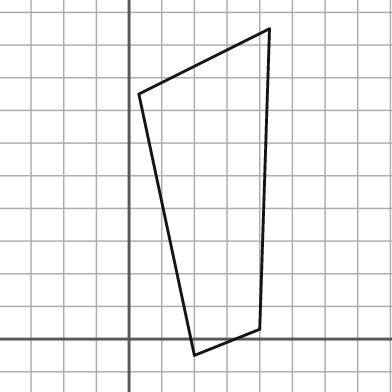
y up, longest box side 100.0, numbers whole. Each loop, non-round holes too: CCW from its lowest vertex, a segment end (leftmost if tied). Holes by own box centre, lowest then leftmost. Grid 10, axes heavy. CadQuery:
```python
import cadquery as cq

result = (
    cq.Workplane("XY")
    .moveTo(20.0, -5.0)
    .lineTo(40.0, 3.0)
    .lineTo(43.0, 95.0)
    .lineTo(3.0, 75.0)
    .close()
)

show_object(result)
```